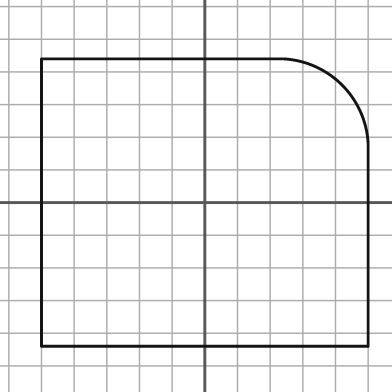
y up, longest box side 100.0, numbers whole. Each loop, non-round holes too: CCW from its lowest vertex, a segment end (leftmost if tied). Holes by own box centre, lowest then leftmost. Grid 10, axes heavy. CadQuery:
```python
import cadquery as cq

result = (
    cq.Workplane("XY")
    .moveTo(-50.0, -44.0)
    .lineTo(50.0, -44.0)
    .lineTo(50.0, 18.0)
    .threePointArc((42.0, 36.0), (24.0, 44.0))
    .lineTo(-50.0, 44.0)
    .close()
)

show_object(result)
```